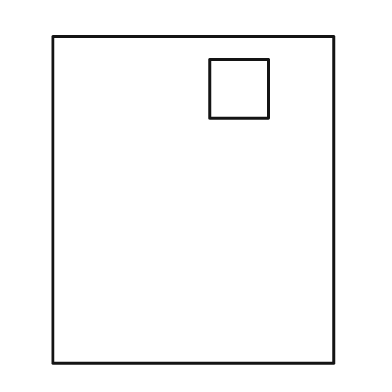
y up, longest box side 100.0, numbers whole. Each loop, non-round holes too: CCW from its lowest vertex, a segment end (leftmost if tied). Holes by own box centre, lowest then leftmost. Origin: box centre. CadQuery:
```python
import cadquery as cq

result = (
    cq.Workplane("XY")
    .moveTo(-43.0, -50.0)
    .lineTo(43.0, -50.0)
    .lineTo(43.0, 50.0)
    .lineTo(-43.0, 50.0)
    .close()
    .moveTo(5.0, 25.0)
    .lineTo(23.0, 25.0)
    .lineTo(23.0, 43.0)
    .lineTo(5.0, 43.0)
    .close()
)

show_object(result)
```